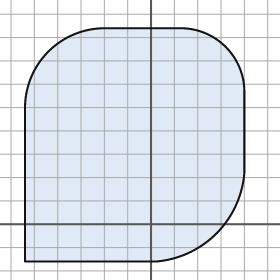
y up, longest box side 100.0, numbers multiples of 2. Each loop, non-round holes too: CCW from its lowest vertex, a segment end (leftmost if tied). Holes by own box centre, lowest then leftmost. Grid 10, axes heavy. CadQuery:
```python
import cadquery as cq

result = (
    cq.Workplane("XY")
    .moveTo(-54.0, -16.0)
    .lineTo(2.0, -16.0)
    .threePointArc((28.0, -4.0), (40.0, 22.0))
    .lineTo(40.0, 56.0)
    .threePointArc((32.0, 76.0), (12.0, 84.0))
    .lineTo(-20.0, 84.0)
    .threePointArc((-44.0, 74.0), (-54.0, 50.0))
    .close()
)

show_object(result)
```